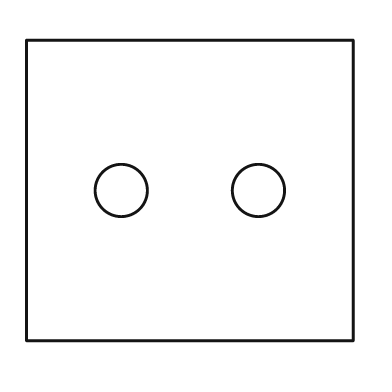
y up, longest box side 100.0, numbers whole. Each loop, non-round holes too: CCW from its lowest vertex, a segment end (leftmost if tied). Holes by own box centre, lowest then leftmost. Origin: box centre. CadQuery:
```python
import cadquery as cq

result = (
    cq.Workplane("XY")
    .moveTo(-50.0, -46.0)
    .lineTo(50.0, -46.0)
    .lineTo(50.0, 46.0)
    .lineTo(-50.0, 46.0)
    .close()
    .moveTo(-21.0, 0.0)
    .circle(8.0)
    .moveTo(21.0, 0.0)
    .circle(8.0)
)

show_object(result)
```